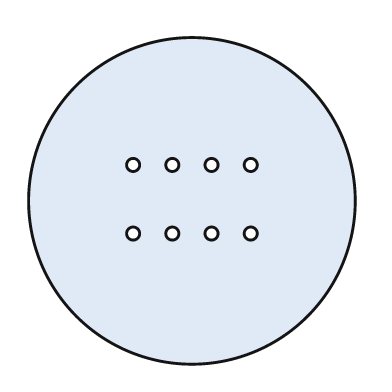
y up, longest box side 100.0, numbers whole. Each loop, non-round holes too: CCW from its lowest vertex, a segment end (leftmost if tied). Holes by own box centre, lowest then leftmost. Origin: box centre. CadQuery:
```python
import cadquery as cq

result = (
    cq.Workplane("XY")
    .moveTo(0.0, 0.0)
    .circle(50.0)
    .moveTo(-18.0, -10.0)
    .circle(2.0)
    .moveTo(-6.0, -10.0)
    .circle(2.0)
    .moveTo(6.0, -10.0)
    .circle(2.0)
    .moveTo(18.0, -10.0)
    .circle(2.0)
    .moveTo(-18.0, 11.0)
    .circle(2.0)
    .moveTo(-6.0, 11.0)
    .circle(2.0)
    .moveTo(6.0, 11.0)
    .circle(2.0)
    .moveTo(18.0, 11.0)
    .circle(2.0)
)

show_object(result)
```